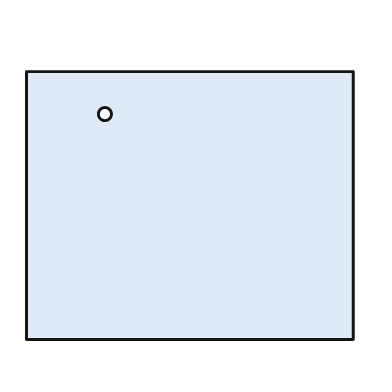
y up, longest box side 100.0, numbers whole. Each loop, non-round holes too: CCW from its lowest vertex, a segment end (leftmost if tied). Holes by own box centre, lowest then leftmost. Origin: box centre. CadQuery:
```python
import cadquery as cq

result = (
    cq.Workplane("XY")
    .moveTo(-50.0, -41.0)
    .lineTo(50.0, -41.0)
    .lineTo(50.0, 41.0)
    .lineTo(-50.0, 41.0)
    .close()
    .moveTo(-26.0, 28.0)
    .circle(2.0)
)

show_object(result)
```